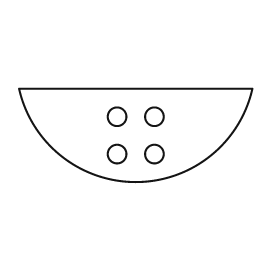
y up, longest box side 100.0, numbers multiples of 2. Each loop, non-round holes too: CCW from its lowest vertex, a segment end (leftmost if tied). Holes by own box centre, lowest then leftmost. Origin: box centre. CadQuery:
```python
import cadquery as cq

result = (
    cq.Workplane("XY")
    .moveTo(-50.0, 20.0)
    .threePointArc((0.0, -20.0), (50.0, 20.0))
    .close()
    .moveTo(-8.0, -8.0)
    .circle(4.0)
    .moveTo(8.0, -8.0)
    .circle(4.0)
    .moveTo(-8.0, 8.0)
    .circle(4.0)
    .moveTo(8.0, 8.0)
    .circle(4.0)
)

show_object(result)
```